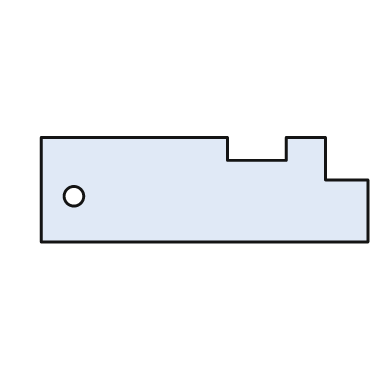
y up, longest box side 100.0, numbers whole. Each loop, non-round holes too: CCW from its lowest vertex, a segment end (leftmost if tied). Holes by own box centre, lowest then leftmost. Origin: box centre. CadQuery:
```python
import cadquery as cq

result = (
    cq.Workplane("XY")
    .moveTo(-50.0, -16.0)
    .lineTo(50.0, -16.0)
    .lineTo(50.0, 3.0)
    .lineTo(37.0, 3.0)
    .lineTo(37.0, 16.0)
    .lineTo(25.0, 16.0)
    .lineTo(25.0, 9.0)
    .lineTo(7.0, 9.0)
    .lineTo(7.0, 16.0)
    .lineTo(-50.0, 16.0)
    .close()
    .moveTo(-40.0, -2.0)
    .circle(3.0)
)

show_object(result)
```